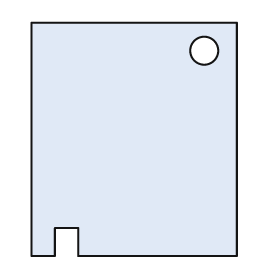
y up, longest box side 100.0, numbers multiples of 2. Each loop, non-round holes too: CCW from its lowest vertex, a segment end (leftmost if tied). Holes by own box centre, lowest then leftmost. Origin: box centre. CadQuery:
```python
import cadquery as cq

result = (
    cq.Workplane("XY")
    .moveTo(-44.0, -50.0)
    .lineTo(-34.0, -50.0)
    .lineTo(-34.0, -38.0)
    .lineTo(-24.0, -38.0)
    .lineTo(-24.0, -50.0)
    .lineTo(44.0, -50.0)
    .lineTo(44.0, 50.0)
    .lineTo(-44.0, 50.0)
    .close()
    .moveTo(30.0, 38.0)
    .circle(6.0)
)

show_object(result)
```